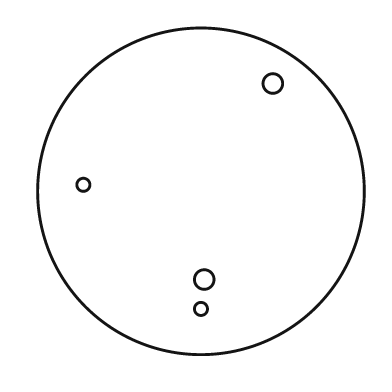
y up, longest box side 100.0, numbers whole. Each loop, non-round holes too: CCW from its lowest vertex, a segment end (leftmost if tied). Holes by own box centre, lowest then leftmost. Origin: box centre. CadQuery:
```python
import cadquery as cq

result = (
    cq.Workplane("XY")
    .moveTo(0.0, 0.0)
    .circle(50.0)
    .moveTo(0.0, -36.0)
    .circle(2.0)
    .moveTo(1.0, -27.0)
    .circle(3.0)
    .moveTo(-36.0, 2.0)
    .circle(2.0)
    .moveTo(22.0, 33.0)
    .circle(3.0)
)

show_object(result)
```